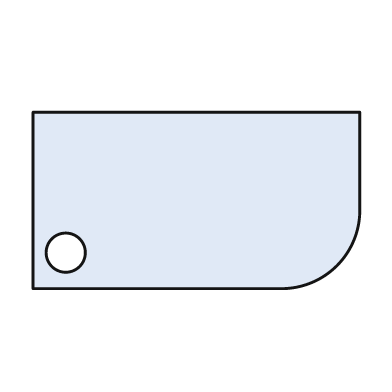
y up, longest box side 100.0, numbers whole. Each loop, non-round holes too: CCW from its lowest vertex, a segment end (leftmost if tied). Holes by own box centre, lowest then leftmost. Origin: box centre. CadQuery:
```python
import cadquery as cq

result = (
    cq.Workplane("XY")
    .moveTo(-50.0, -27.0)
    .lineTo(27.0, -27.0)
    .threePointArc((43.0, -20.0), (50.0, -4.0))
    .lineTo(50.0, 27.0)
    .lineTo(-50.0, 27.0)
    .close()
    .moveTo(-40.0, -16.0)
    .circle(6.0)
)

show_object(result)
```